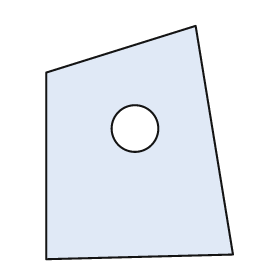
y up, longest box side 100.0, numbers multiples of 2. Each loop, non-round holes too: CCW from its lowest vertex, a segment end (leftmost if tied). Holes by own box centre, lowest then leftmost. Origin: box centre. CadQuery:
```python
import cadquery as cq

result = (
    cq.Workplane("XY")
    .moveTo(-40.0, -50.0)
    .lineTo(40.0, -48.0)
    .lineTo(24.0, 50.0)
    .lineTo(-40.0, 30.0)
    .close()
    .moveTo(-2.0, 6.0)
    .circle(10.0)
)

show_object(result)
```